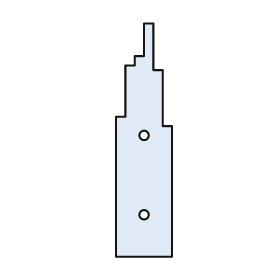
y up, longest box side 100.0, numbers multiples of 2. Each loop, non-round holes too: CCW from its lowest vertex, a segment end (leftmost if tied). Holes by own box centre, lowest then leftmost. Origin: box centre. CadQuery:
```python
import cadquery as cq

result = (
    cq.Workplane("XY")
    .moveTo(-12.0, -50.0)
    .lineTo(12.0, -50.0)
    .lineTo(12.0, 6.0)
    .lineTo(8.0, 6.0)
    .lineTo(8.0, 30.0)
    .lineTo(4.0, 30.0)
    .lineTo(4.0, 50.0)
    .lineTo(0.0, 50.0)
    .lineTo(0.0, 36.0)
    .lineTo(-4.0, 36.0)
    .lineTo(-4.0, 32.0)
    .lineTo(-8.0, 32.0)
    .lineTo(-8.0, 10.0)
    .lineTo(-12.0, 10.0)
    .close()
    .moveTo(0.0, -32.0)
    .circle(2.0)
    .moveTo(0.0, 2.0)
    .circle(2.0)
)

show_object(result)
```